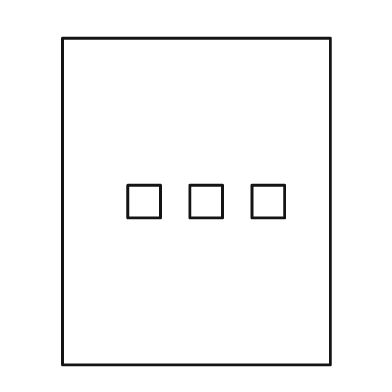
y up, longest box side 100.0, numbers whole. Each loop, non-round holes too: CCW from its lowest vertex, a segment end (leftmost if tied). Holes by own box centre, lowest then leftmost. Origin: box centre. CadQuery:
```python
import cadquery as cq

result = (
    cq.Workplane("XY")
    .moveTo(-41.0, -50.0)
    .lineTo(41.0, -50.0)
    .lineTo(41.0, 50.0)
    .lineTo(-41.0, 50.0)
    .close()
    .moveTo(-21.0, -5.0)
    .lineTo(-11.0, -5.0)
    .lineTo(-11.0, 5.0)
    .lineTo(-21.0, 5.0)
    .close()
    .moveTo(-2.0, -5.0)
    .lineTo(8.0, -5.0)
    .lineTo(8.0, 5.0)
    .lineTo(-2.0, 5.0)
    .close()
    .moveTo(17.0, -5.0)
    .lineTo(27.0, -5.0)
    .lineTo(27.0, 5.0)
    .lineTo(17.0, 5.0)
    .close()
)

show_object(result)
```